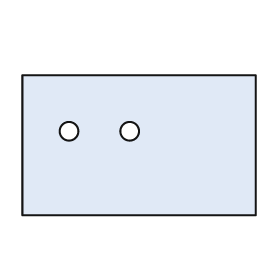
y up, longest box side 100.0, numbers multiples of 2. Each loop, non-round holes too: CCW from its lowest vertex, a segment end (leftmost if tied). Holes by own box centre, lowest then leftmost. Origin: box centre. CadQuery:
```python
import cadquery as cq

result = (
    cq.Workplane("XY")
    .moveTo(-50.0, -30.0)
    .lineTo(50.0, -30.0)
    .lineTo(50.0, 30.0)
    .lineTo(-50.0, 30.0)
    .close()
    .moveTo(-30.0, 6.0)
    .circle(4.0)
    .moveTo(-4.0, 6.0)
    .circle(4.0)
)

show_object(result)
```